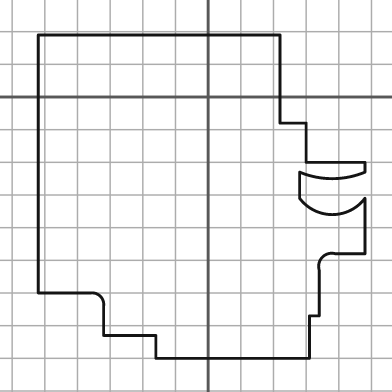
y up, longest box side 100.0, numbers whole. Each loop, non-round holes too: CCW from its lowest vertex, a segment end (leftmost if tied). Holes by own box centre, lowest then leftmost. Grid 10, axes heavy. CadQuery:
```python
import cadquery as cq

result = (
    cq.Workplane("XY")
    .moveTo(-16.0, -80.0)
    .lineTo(31.0, -80.0)
    .lineTo(31.0, -67.0)
    .lineTo(34.0, -67.0)
    .lineTo(34.0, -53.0)
    .threePointArc((35.0, -49.0), (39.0, -48.0))
    .lineTo(48.0, -48.0)
    .lineTo(48.0, -31.0)
    .threePointArc((38.0, -36.0), (28.0, -31.0))
    .lineTo(28.0, -23.0)
    .threePointArc((38.0, -25.0), (48.0, -23.0))
    .lineTo(48.0, -20.0)
    .lineTo(30.0, -20.0)
    .lineTo(30.0, -8.0)
    .lineTo(22.0, -8.0)
    .lineTo(22.0, 19.0)
    .lineTo(-52.0, 19.0)
    .lineTo(-52.0, -60.0)
    .lineTo(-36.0, -60.0)
    .threePointArc((-33.0, -61.0), (-32.0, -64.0))
    .lineTo(-32.0, -73.0)
    .lineTo(-16.0, -73.0)
    .close()
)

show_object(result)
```